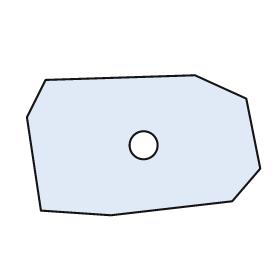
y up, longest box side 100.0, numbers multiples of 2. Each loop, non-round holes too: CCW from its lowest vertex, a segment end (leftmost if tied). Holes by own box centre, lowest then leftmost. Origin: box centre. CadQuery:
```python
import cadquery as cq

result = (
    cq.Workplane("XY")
    .moveTo(-14.0, -30.0)
    .lineTo(38.0, -24.0)
    .lineTo(50.0, -10.0)
    .lineTo(44.0, 20.0)
    .lineTo(22.0, 30.0)
    .lineTo(-42.0, 28.0)
    .lineTo(-50.0, 12.0)
    .lineTo(-44.0, -28.0)
    .close()
    .moveTo(0.0, 0.0)
    .circle(6.0)
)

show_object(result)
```